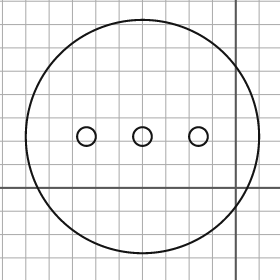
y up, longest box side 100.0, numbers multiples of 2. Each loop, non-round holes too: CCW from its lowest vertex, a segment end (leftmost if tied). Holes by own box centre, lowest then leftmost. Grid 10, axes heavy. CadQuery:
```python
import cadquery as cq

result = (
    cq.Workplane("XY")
    .moveTo(-40.0, 22.0)
    .circle(50.0)
    .moveTo(-64.0, 22.0)
    .circle(4.0)
    .moveTo(-40.0, 22.0)
    .circle(4.0)
    .moveTo(-16.0, 22.0)
    .circle(4.0)
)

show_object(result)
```